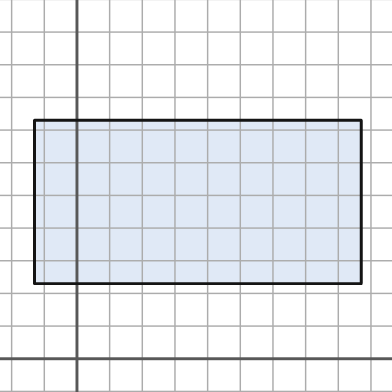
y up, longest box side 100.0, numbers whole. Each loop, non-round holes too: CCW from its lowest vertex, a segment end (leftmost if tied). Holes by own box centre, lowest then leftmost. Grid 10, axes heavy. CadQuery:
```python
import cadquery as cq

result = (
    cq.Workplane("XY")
    .moveTo(-13.0, 23.0)
    .lineTo(87.0, 23.0)
    .lineTo(87.0, 73.0)
    .lineTo(-13.0, 73.0)
    .close()
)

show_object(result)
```